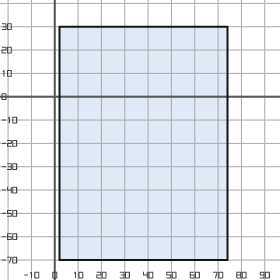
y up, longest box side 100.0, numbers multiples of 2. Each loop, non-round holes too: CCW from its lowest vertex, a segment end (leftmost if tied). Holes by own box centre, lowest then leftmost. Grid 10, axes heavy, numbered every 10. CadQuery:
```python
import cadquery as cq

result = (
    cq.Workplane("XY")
    .moveTo(2.0, -70.0)
    .lineTo(74.0, -70.0)
    .lineTo(74.0, 30.0)
    .lineTo(2.0, 30.0)
    .close()
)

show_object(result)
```